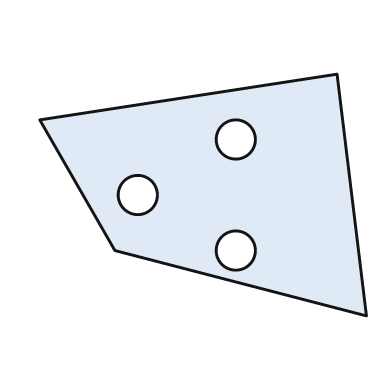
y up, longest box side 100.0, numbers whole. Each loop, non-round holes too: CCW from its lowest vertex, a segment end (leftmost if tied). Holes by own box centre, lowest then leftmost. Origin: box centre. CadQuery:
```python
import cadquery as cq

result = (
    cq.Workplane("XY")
    .moveTo(50.0, -37.0)
    .lineTo(41.0, 37.0)
    .lineTo(-50.0, 23.0)
    .lineTo(-27.0, -17.0)
    .close()
    .moveTo(10.0, -17.0)
    .circle(6.0)
    .moveTo(-20.0, 0.0)
    .circle(6.0)
    .moveTo(10.0, 17.0)
    .circle(6.0)
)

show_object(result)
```